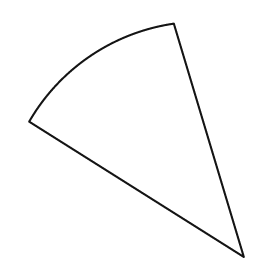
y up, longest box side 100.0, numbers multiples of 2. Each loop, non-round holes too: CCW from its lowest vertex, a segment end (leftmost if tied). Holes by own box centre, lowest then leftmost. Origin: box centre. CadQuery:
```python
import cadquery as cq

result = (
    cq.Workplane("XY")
    .moveTo(46.0, -50.0)
    .lineTo(16.0, 50.0)
    .threePointArc((-20.0, 36.0), (-46.0, 8.0))
    .close()
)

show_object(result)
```